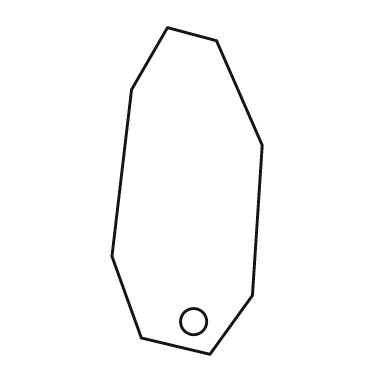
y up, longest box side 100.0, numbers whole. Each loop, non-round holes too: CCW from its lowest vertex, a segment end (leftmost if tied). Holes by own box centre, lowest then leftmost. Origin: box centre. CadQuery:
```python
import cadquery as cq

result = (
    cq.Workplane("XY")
    .moveTo(7.0, -50.0)
    .lineTo(20.0, -32.0)
    .lineTo(23.0, 14.0)
    .lineTo(9.0, 46.0)
    .lineTo(-6.0, 50.0)
    .lineTo(-17.0, 31.0)
    .lineTo(-23.0, -20.0)
    .lineTo(-14.0, -45.0)
    .close()
    .moveTo(2.0, -40.0)
    .circle(4.0)
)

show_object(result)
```